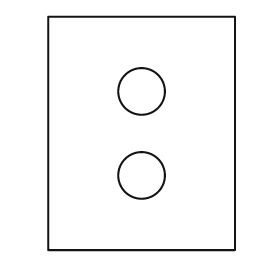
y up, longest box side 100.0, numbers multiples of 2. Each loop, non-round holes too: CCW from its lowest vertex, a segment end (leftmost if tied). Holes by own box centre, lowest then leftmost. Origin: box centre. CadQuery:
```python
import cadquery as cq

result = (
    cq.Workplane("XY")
    .moveTo(-40.0, -50.0)
    .lineTo(40.0, -50.0)
    .lineTo(40.0, 50.0)
    .lineTo(-40.0, 50.0)
    .close()
    .moveTo(0.0, -18.0)
    .circle(10.0)
    .moveTo(0.0, 18.0)
    .circle(10.0)
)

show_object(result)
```